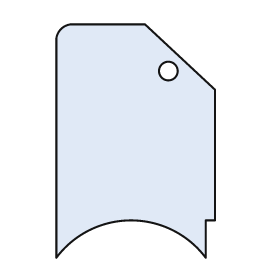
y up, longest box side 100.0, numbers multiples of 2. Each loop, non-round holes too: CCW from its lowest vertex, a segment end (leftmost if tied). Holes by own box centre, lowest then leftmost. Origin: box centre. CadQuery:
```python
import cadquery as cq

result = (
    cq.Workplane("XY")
    .moveTo(-34.0, -50.0)
    .threePointArc((-2.0, -34.0), (30.0, -50.0))
    .lineTo(30.0, -34.0)
    .lineTo(34.0, -34.0)
    .lineTo(34.0, 22.0)
    .lineTo(4.0, 50.0)
    .lineTo(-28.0, 50.0)
    .threePointArc((-32.0, 48.0), (-34.0, 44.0))
    .close()
    .moveTo(14.0, 30.0)
    .circle(4.0)
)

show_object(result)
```